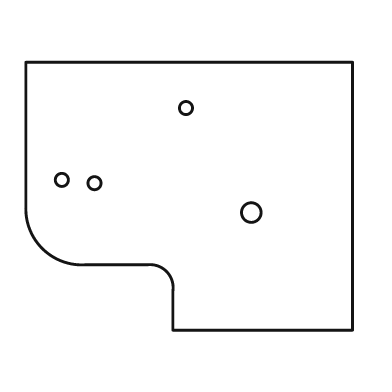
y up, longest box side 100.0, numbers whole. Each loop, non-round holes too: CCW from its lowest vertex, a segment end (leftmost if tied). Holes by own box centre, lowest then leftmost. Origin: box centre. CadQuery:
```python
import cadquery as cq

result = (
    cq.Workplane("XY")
    .moveTo(-5.0, -41.0)
    .lineTo(50.0, -41.0)
    .lineTo(50.0, 41.0)
    .lineTo(-50.0, 41.0)
    .lineTo(-50.0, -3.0)
    .threePointArc((-45.0, -16.0), (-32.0, -21.0))
    .lineTo(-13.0, -21.0)
    .threePointArc((-7.0, -23.0), (-5.0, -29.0))
    .close()
    .moveTo(19.0, -5.0)
    .circle(3.0)
    .moveTo(-29.0, 4.0)
    .circle(2.0)
    .moveTo(-39.0, 5.0)
    .circle(2.0)
    .moveTo(-1.0, 27.0)
    .circle(2.0)
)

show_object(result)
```